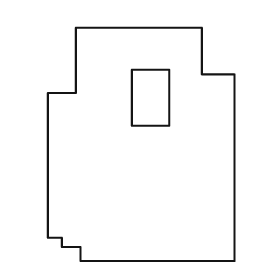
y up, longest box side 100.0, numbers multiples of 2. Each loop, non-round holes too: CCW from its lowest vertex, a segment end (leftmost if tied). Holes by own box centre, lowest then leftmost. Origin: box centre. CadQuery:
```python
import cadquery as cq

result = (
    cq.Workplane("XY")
    .moveTo(-26.0, -50.0)
    .lineTo(40.0, -50.0)
    .lineTo(40.0, 30.0)
    .lineTo(26.0, 30.0)
    .lineTo(26.0, 50.0)
    .lineTo(-28.0, 50.0)
    .lineTo(-28.0, 22.0)
    .lineTo(-40.0, 22.0)
    .lineTo(-40.0, -40.0)
    .lineTo(-34.0, -40.0)
    .lineTo(-34.0, -44.0)
    .lineTo(-26.0, -44.0)
    .close()
    .moveTo(-4.0, 8.0)
    .lineTo(12.0, 8.0)
    .lineTo(12.0, 32.0)
    .lineTo(-4.0, 32.0)
    .close()
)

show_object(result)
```